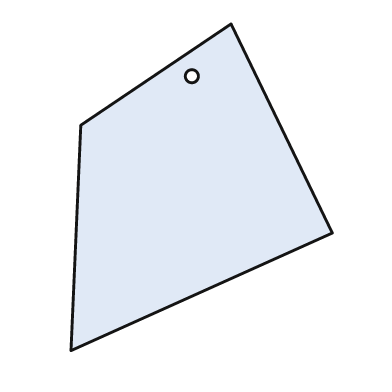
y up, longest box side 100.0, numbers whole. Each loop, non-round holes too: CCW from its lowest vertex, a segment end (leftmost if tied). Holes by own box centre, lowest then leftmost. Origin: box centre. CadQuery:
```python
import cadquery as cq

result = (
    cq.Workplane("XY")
    .moveTo(-40.0, -50.0)
    .lineTo(40.0, -14.0)
    .lineTo(9.0, 50.0)
    .lineTo(-37.0, 19.0)
    .close()
    .moveTo(-3.0, 34.0)
    .circle(2.0)
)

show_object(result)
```